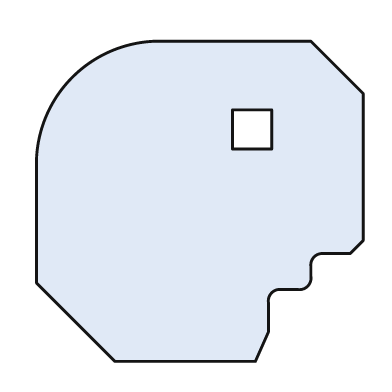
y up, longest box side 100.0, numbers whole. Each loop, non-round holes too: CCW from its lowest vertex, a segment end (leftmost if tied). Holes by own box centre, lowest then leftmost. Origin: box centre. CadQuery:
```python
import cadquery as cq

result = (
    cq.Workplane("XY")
    .moveTo(-26.0, -49.0)
    .lineTo(17.0, -49.0)
    .lineTo(21.0, -40.0)
    .lineTo(21.0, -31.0)
    .threePointArc((22.0, -28.0), (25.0, -27.0))
    .lineTo(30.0, -27.0)
    .threePointArc((33.0, -26.0), (34.0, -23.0))
    .lineTo(34.0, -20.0)
    .threePointArc((35.0, -17.0), (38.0, -16.0))
    .lineTo(46.0, -16.0)
    .lineTo(50.0, -12.0)
    .lineTo(50.0, 33.0)
    .lineTo(34.0, 49.0)
    .lineTo(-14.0, 49.0)
    .threePointArc((-39.0, 38.0), (-50.0, 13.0))
    .lineTo(-50.0, -25.0)
    .close()
    .moveTo(10.0, 16.0)
    .lineTo(22.0, 16.0)
    .lineTo(22.0, 28.0)
    .lineTo(10.0, 28.0)
    .close()
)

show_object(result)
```